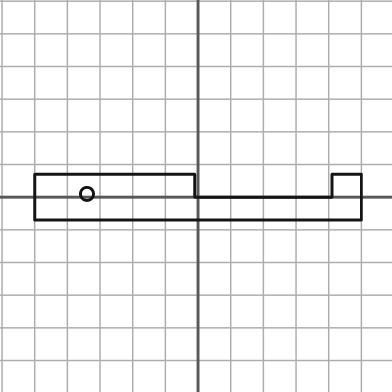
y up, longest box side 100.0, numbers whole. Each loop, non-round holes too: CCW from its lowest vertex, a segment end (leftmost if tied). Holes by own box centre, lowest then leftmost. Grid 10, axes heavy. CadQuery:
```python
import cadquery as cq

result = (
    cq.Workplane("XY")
    .moveTo(-50.0, -7.0)
    .lineTo(50.0, -7.0)
    .lineTo(50.0, 7.0)
    .lineTo(41.0, 7.0)
    .lineTo(41.0, 0.0)
    .lineTo(-1.0, 0.0)
    .lineTo(-1.0, 7.0)
    .lineTo(-50.0, 7.0)
    .close()
    .moveTo(-34.0, 1.0)
    .circle(2.0)
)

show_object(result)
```